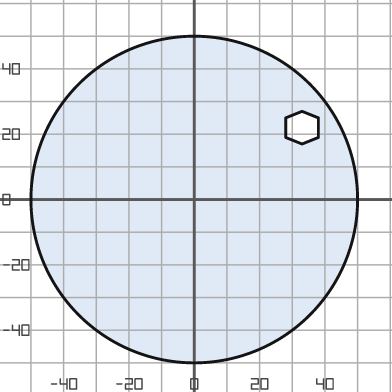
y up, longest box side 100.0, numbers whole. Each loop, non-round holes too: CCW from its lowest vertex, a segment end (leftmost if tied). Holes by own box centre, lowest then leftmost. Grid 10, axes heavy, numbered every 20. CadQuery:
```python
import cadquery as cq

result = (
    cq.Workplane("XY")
    .moveTo(0.0, 0.0)
    .circle(50.0)
    .moveTo(33.0, 17.0)
    .lineTo(38.0, 19.0)
    .lineTo(38.0, 25.0)
    .lineTo(33.0, 27.0)
    .lineTo(28.0, 25.0)
    .lineTo(28.0, 19.0)
    .close()
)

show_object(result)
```